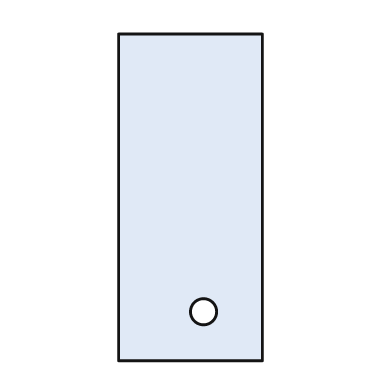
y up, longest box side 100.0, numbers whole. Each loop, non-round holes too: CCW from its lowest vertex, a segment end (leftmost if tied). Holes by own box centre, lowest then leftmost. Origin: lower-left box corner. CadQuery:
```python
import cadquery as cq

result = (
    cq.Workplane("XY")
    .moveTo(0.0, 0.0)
    .lineTo(44.0, 0.0)
    .lineTo(44.0, 100.0)
    .lineTo(0.0, 100.0)
    .close()
    .moveTo(26.0, 15.0)
    .circle(4.0)
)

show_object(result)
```